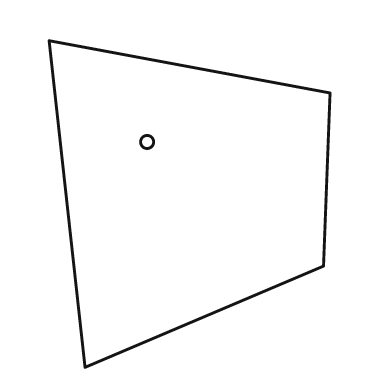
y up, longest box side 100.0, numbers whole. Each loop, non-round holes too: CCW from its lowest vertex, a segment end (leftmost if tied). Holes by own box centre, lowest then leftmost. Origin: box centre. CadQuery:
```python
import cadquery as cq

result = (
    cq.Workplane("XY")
    .moveTo(-32.0, -50.0)
    .lineTo(41.0, -19.0)
    .lineTo(43.0, 34.0)
    .lineTo(-43.0, 50.0)
    .close()
    .moveTo(-13.0, 19.0)
    .circle(2.0)
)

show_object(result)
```